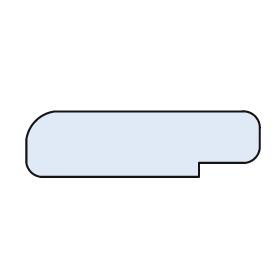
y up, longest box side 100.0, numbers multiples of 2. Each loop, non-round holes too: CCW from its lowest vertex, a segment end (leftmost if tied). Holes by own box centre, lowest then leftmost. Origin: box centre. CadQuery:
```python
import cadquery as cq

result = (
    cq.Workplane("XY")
    .moveTo(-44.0, -14.0)
    .lineTo(24.0, -14.0)
    .lineTo(24.0, -8.0)
    .lineTo(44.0, -8.0)
    .threePointArc((48.0, -6.0), (50.0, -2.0))
    .lineTo(50.0, 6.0)
    .threePointArc((48.0, 12.0), (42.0, 14.0))
    .lineTo(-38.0, 14.0)
    .threePointArc((-46.0, 10.0), (-50.0, 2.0))
    .lineTo(-50.0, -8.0)
    .threePointArc((-48.0, -12.0), (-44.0, -14.0))
    .close()
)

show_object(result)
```